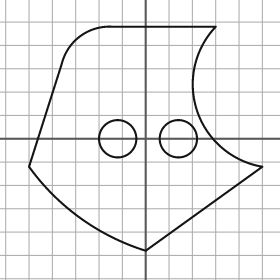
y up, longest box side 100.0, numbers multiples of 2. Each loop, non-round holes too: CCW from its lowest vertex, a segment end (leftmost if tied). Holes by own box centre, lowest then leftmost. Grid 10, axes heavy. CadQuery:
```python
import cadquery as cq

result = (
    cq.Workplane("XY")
    .moveTo(0.0, -48.0)
    .lineTo(50.0, -12.0)
    .threePointArc((22.0, 12.0), (30.0, 48.0))
    .lineTo(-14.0, 48.0)
    .threePointArc((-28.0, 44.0), (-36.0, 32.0))
    .lineTo(-50.0, -12.0)
    .threePointArc((-28.0, -34.0), (0.0, -48.0))
    .close()
    .moveTo(-12.0, 0.0)
    .circle(8.0)
    .moveTo(14.0, 0.0)
    .circle(8.0)
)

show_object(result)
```